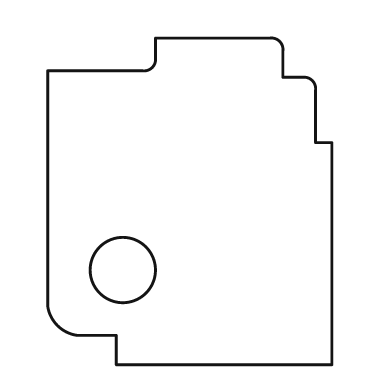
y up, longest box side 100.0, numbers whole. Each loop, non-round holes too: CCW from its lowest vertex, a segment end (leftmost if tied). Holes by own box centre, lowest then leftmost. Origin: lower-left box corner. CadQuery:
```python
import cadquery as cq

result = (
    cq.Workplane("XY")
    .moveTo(21.0, 0.0)
    .lineTo(87.0, 0.0)
    .lineTo(87.0, 68.0)
    .lineTo(82.0, 68.0)
    .lineTo(82.0, 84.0)
    .threePointArc((81.0, 87.0), (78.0, 88.0))
    .lineTo(72.0, 88.0)
    .lineTo(72.0, 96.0)
    .threePointArc((71.0, 99.0), (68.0, 100.0))
    .lineTo(33.0, 100.0)
    .lineTo(33.0, 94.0)
    .threePointArc((32.0, 91.0), (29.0, 90.0))
    .lineTo(0.0, 90.0)
    .lineTo(0.0, 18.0)
    .threePointArc((3.0, 12.0), (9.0, 9.0))
    .lineTo(21.0, 9.0)
    .close()
    .moveTo(23.0, 29.0)
    .circle(10.0)
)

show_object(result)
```